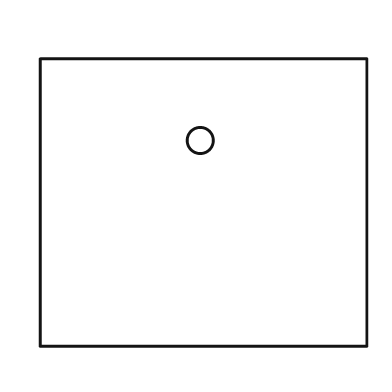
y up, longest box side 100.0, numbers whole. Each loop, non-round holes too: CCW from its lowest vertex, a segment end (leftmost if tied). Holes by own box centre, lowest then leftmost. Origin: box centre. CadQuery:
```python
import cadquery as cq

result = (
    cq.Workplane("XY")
    .moveTo(-50.0, -44.0)
    .lineTo(50.0, -44.0)
    .lineTo(50.0, 44.0)
    .lineTo(-50.0, 44.0)
    .close()
    .moveTo(-1.0, 19.0)
    .circle(4.0)
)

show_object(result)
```